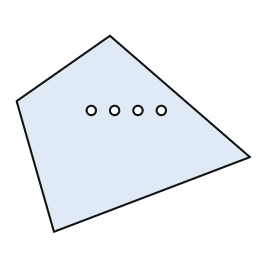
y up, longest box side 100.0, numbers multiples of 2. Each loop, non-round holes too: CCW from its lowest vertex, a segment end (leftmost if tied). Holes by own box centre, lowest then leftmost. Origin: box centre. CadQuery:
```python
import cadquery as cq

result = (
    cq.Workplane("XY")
    .moveTo(-34.0, -42.0)
    .lineTo(50.0, -10.0)
    .lineTo(-10.0, 42.0)
    .lineTo(-50.0, 14.0)
    .close()
    .moveTo(-18.0, 10.0)
    .circle(2.0)
    .moveTo(-8.0, 10.0)
    .circle(2.0)
    .moveTo(2.0, 10.0)
    .circle(2.0)
    .moveTo(12.0, 10.0)
    .circle(2.0)
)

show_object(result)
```